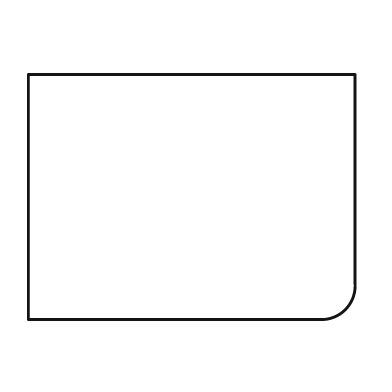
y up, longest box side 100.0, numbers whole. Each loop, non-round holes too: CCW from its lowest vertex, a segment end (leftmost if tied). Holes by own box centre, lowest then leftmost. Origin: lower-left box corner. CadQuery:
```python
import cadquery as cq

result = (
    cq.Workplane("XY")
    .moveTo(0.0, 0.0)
    .lineTo(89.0, 0.0)
    .threePointArc((97.0, 3.0), (100.0, 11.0))
    .lineTo(100.0, 75.0)
    .lineTo(0.0, 75.0)
    .close()
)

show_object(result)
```